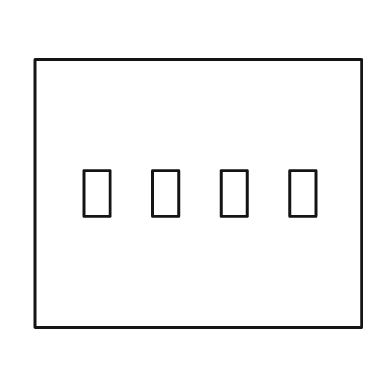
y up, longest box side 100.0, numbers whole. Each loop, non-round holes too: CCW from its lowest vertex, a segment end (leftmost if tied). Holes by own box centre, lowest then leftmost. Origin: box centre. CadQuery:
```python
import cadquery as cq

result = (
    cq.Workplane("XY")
    .moveTo(-50.0, -41.0)
    .lineTo(50.0, -41.0)
    .lineTo(50.0, 41.0)
    .lineTo(-50.0, 41.0)
    .close()
    .moveTo(-35.0, -7.0)
    .lineTo(-27.0, -7.0)
    .lineTo(-27.0, 7.0)
    .lineTo(-35.0, 7.0)
    .close()
    .moveTo(-14.0, -7.0)
    .lineTo(-6.0, -7.0)
    .lineTo(-6.0, 7.0)
    .lineTo(-14.0, 7.0)
    .close()
    .moveTo(7.0, -7.0)
    .lineTo(15.0, -7.0)
    .lineTo(15.0, 7.0)
    .lineTo(7.0, 7.0)
    .close()
    .moveTo(28.0, -7.0)
    .lineTo(36.0, -7.0)
    .lineTo(36.0, 7.0)
    .lineTo(28.0, 7.0)
    .close()
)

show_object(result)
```